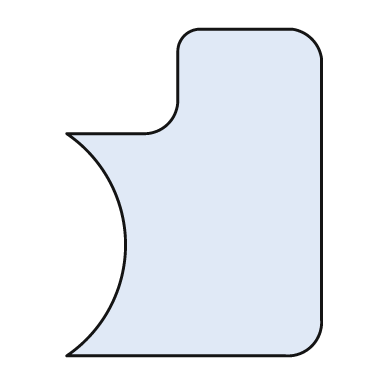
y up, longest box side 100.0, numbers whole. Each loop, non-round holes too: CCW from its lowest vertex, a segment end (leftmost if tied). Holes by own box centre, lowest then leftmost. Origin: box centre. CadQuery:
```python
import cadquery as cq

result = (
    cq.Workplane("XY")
    .moveTo(-39.0, -50.0)
    .lineTo(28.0, -50.0)
    .threePointArc((36.0, -47.0), (39.0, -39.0))
    .lineTo(39.0, 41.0)
    .threePointArc((36.0, 47.0), (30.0, 50.0))
    .lineTo(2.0, 50.0)
    .threePointArc((-3.0, 48.0), (-5.0, 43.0))
    .lineTo(-5.0, 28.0)
    .threePointArc((-8.0, 21.0), (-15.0, 18.0))
    .lineTo(-39.0, 18.0)
    .threePointArc((-21.0, -16.0), (-39.0, -50.0))
    .close()
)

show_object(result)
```